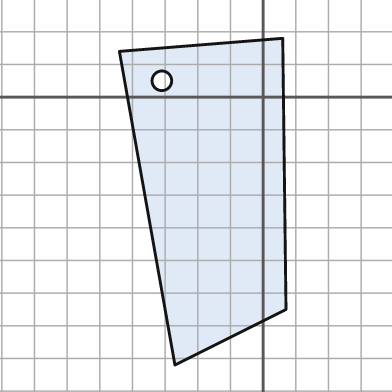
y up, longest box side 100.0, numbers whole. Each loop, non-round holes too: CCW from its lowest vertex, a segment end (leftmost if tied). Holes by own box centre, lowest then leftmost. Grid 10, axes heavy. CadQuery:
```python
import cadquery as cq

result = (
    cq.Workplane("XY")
    .moveTo(-27.0, -82.0)
    .lineTo(7.0, -65.0)
    .lineTo(6.0, 18.0)
    .lineTo(-44.0, 14.0)
    .close()
    .moveTo(-31.0, 5.0)
    .circle(3.0)
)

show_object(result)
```